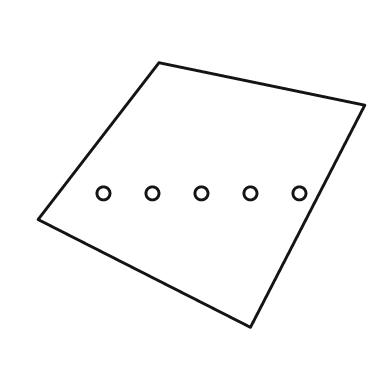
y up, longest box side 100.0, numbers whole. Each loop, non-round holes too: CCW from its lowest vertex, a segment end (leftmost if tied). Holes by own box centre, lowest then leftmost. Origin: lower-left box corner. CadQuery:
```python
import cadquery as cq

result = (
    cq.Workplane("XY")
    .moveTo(65.0, 0.0)
    .lineTo(100.0, 68.0)
    .lineTo(37.0, 81.0)
    .lineTo(0.0, 33.0)
    .close()
    .moveTo(20.0, 41.0)
    .circle(2.0)
    .moveTo(35.0, 41.0)
    .circle(2.0)
    .moveTo(50.0, 41.0)
    .circle(2.0)
    .moveTo(65.0, 41.0)
    .circle(2.0)
    .moveTo(80.0, 41.0)
    .circle(2.0)
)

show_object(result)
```